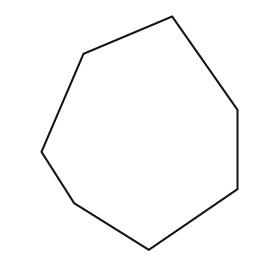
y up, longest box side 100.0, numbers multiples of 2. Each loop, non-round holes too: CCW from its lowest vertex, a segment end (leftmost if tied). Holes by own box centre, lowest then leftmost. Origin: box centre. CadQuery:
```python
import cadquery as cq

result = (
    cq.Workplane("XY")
    .moveTo(4.0, -50.0)
    .lineTo(42.0, -24.0)
    .lineTo(42.0, 10.0)
    .lineTo(14.0, 50.0)
    .lineTo(-24.0, 34.0)
    .lineTo(-42.0, -8.0)
    .lineTo(-28.0, -30.0)
    .close()
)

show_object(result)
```